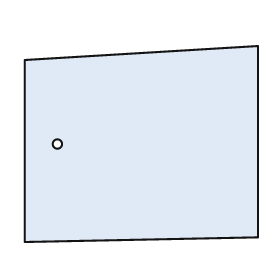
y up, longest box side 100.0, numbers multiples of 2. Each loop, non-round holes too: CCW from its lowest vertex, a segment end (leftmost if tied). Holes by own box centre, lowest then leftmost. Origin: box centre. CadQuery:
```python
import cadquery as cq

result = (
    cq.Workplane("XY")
    .moveTo(-50.0, -42.0)
    .lineTo(50.0, -40.0)
    .lineTo(50.0, 42.0)
    .lineTo(-50.0, 36.0)
    .close()
    .moveTo(-36.0, 0.0)
    .circle(2.0)
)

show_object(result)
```